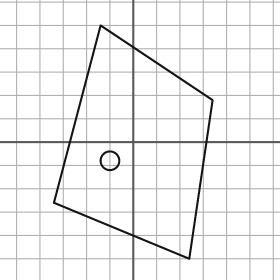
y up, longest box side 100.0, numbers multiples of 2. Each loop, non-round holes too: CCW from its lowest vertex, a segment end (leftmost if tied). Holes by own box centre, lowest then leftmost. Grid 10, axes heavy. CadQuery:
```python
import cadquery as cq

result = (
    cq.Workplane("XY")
    .moveTo(24.0, -50.0)
    .lineTo(34.0, 18.0)
    .lineTo(-14.0, 50.0)
    .lineTo(-34.0, -26.0)
    .close()
    .moveTo(-10.0, -8.0)
    .circle(4.0)
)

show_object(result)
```